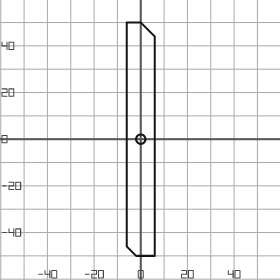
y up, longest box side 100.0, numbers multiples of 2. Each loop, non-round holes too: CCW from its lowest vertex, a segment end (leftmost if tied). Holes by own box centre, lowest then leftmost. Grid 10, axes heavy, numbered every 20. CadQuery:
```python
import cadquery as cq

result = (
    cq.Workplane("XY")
    .moveTo(-2.0, -50.0)
    .lineTo(6.0, -50.0)
    .lineTo(6.0, 44.0)
    .lineTo(0.0, 50.0)
    .lineTo(-6.0, 50.0)
    .lineTo(-6.0, -46.0)
    .close()
    .moveTo(0.0, 0.0)
    .circle(2.0)
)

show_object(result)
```